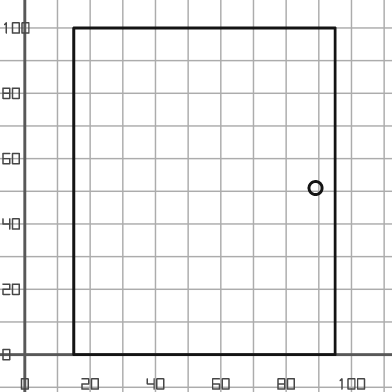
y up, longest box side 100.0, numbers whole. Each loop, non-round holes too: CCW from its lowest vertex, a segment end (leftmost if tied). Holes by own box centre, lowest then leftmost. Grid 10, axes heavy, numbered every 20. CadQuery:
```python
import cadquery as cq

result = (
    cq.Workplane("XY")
    .moveTo(15.0, 0.0)
    .lineTo(95.0, 0.0)
    .lineTo(95.0, 100.0)
    .lineTo(15.0, 100.0)
    .close()
    .moveTo(89.0, 51.0)
    .circle(2.0)
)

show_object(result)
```